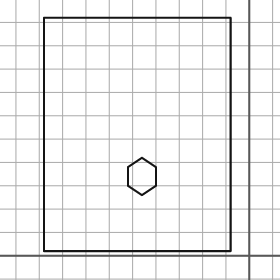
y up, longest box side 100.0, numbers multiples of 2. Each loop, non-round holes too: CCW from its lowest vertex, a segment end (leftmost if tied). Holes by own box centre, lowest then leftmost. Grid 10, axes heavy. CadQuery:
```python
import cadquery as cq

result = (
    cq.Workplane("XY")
    .moveTo(-88.0, 2.0)
    .lineTo(-8.0, 2.0)
    .lineTo(-8.0, 102.0)
    .lineTo(-88.0, 102.0)
    .close()
    .moveTo(-46.0, 26.0)
    .lineTo(-40.0, 30.0)
    .lineTo(-40.0, 38.0)
    .lineTo(-46.0, 42.0)
    .lineTo(-52.0, 38.0)
    .lineTo(-52.0, 30.0)
    .close()
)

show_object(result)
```